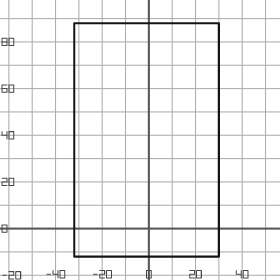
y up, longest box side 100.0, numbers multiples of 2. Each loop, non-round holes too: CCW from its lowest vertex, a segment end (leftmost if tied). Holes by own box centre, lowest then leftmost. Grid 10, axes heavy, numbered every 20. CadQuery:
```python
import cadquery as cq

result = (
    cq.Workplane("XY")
    .moveTo(-32.0, -12.0)
    .lineTo(30.0, -12.0)
    .lineTo(30.0, 88.0)
    .lineTo(-32.0, 88.0)
    .close()
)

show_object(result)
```